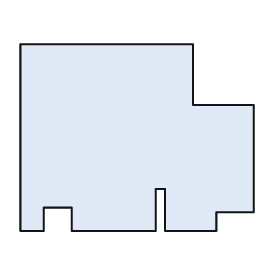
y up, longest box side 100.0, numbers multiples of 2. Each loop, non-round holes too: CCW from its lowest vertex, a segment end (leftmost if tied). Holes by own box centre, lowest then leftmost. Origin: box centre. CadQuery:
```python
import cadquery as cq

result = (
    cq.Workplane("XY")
    .moveTo(-50.0, -40.0)
    .lineTo(-40.0, -40.0)
    .lineTo(-40.0, -30.0)
    .lineTo(-28.0, -30.0)
    .lineTo(-28.0, -40.0)
    .lineTo(8.0, -40.0)
    .lineTo(8.0, -22.0)
    .lineTo(12.0, -22.0)
    .lineTo(12.0, -40.0)
    .lineTo(34.0, -40.0)
    .lineTo(34.0, -32.0)
    .lineTo(50.0, -32.0)
    .lineTo(50.0, 14.0)
    .lineTo(24.0, 14.0)
    .lineTo(24.0, 40.0)
    .lineTo(-50.0, 40.0)
    .close()
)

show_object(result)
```